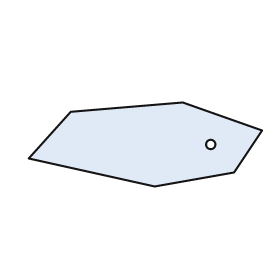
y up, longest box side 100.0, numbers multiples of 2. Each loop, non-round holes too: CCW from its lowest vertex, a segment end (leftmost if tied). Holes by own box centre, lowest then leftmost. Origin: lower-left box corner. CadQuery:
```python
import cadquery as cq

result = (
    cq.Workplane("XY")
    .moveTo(54.0, 0.0)
    .lineTo(88.0, 6.0)
    .lineTo(100.0, 24.0)
    .lineTo(66.0, 36.0)
    .lineTo(18.0, 32.0)
    .lineTo(0.0, 12.0)
    .close()
    .moveTo(78.0, 18.0)
    .circle(2.0)
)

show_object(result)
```